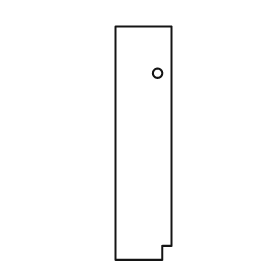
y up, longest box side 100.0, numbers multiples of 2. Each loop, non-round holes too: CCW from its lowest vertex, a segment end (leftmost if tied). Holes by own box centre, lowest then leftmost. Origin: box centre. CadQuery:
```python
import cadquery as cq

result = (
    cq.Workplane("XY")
    .moveTo(-12.0, -50.0)
    .lineTo(8.0, -50.0)
    .lineTo(8.0, -44.0)
    .lineTo(12.0, -44.0)
    .lineTo(12.0, 50.0)
    .lineTo(-12.0, 50.0)
    .close()
    .moveTo(6.0, 30.0)
    .circle(2.0)
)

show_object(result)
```